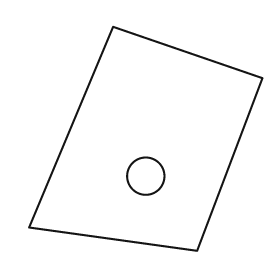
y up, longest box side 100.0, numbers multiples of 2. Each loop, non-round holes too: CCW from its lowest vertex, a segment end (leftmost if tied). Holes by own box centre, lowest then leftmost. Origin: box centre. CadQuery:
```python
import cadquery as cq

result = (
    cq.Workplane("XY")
    .moveTo(22.0, -48.0)
    .lineTo(50.0, 26.0)
    .lineTo(-14.0, 48.0)
    .lineTo(-50.0, -38.0)
    .close()
    .moveTo(0.0, -16.0)
    .circle(8.0)
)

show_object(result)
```